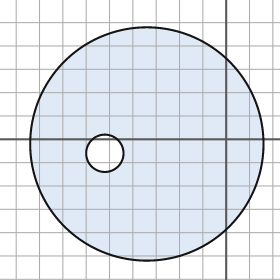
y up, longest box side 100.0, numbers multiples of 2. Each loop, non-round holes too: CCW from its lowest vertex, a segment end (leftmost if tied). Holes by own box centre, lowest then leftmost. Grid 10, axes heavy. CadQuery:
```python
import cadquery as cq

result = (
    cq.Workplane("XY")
    .moveTo(-34.0, -2.0)
    .circle(50.0)
    .moveTo(-52.0, -6.0)
    .circle(8.0)
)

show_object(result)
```